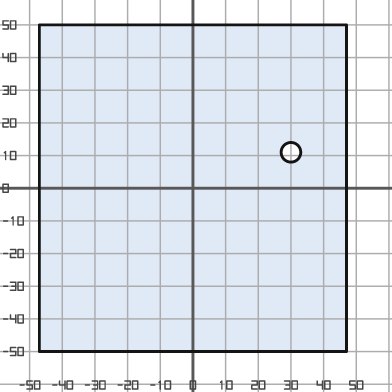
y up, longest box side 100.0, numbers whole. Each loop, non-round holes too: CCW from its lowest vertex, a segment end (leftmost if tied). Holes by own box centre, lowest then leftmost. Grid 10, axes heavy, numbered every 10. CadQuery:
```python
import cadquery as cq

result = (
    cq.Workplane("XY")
    .moveTo(-47.0, -50.0)
    .lineTo(47.0, -50.0)
    .lineTo(47.0, 50.0)
    .lineTo(-47.0, 50.0)
    .close()
    .moveTo(30.0, 11.0)
    .circle(3.0)
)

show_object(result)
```